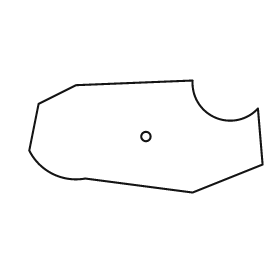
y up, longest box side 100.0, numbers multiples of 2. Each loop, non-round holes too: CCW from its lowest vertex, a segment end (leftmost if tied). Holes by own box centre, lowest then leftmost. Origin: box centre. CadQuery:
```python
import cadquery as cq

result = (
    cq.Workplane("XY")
    .moveTo(20.0, -24.0)
    .lineTo(50.0, -12.0)
    .lineTo(48.0, 12.0)
    .threePointArc((30.0, 8.0), (20.0, 24.0))
    .lineTo(-30.0, 22.0)
    .lineTo(-46.0, 14.0)
    .lineTo(-50.0, -6.0)
    .threePointArc((-40.0, -16.0), (-26.0, -18.0))
    .close()
    .moveTo(0.0, 0.0)
    .circle(2.0)
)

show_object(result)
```